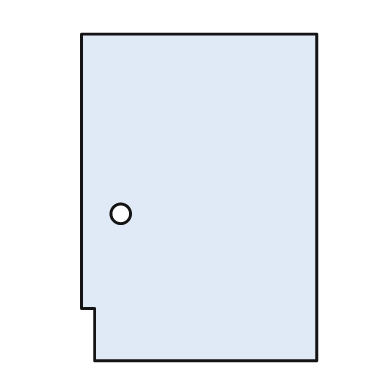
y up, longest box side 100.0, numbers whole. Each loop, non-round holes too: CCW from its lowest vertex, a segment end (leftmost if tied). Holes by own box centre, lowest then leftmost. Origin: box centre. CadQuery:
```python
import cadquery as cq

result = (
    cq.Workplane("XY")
    .moveTo(-32.0, -50.0)
    .lineTo(36.0, -50.0)
    .lineTo(36.0, 50.0)
    .lineTo(-36.0, 50.0)
    .lineTo(-36.0, -34.0)
    .lineTo(-32.0, -34.0)
    .close()
    .moveTo(-24.0, -5.0)
    .circle(3.0)
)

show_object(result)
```